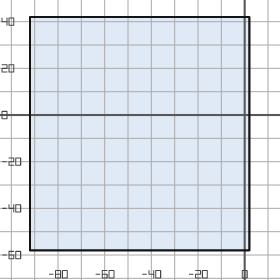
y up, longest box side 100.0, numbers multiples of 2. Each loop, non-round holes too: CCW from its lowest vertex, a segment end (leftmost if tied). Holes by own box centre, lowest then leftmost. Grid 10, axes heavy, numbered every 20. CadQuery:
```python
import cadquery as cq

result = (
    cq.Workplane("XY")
    .moveTo(-92.0, -58.0)
    .lineTo(2.0, -58.0)
    .lineTo(2.0, 42.0)
    .lineTo(-92.0, 42.0)
    .close()
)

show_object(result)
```